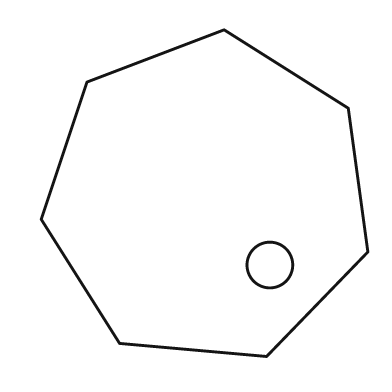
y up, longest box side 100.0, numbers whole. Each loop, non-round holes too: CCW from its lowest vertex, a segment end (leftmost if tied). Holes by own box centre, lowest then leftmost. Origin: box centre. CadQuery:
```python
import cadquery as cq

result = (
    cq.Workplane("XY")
    .moveTo(19.0, -50.0)
    .lineTo(50.0, -18.0)
    .lineTo(44.0, 26.0)
    .lineTo(6.0, 50.0)
    .lineTo(-36.0, 34.0)
    .lineTo(-50.0, -8.0)
    .lineTo(-26.0, -46.0)
    .close()
    .moveTo(20.0, -22.0)
    .circle(7.0)
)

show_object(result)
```